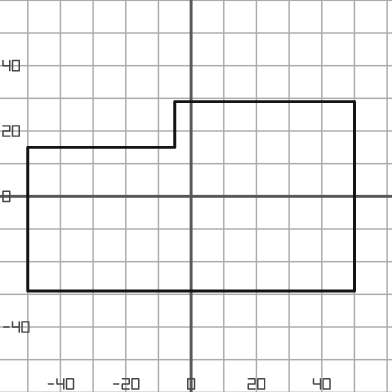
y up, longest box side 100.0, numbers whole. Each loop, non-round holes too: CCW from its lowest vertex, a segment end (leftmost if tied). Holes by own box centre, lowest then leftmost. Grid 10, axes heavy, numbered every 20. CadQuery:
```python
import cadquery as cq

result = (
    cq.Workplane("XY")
    .moveTo(-50.0, -29.0)
    .lineTo(50.0, -29.0)
    .lineTo(50.0, 29.0)
    .lineTo(-5.0, 29.0)
    .lineTo(-5.0, 15.0)
    .lineTo(-50.0, 15.0)
    .close()
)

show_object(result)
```